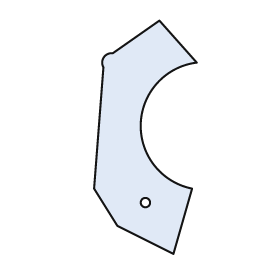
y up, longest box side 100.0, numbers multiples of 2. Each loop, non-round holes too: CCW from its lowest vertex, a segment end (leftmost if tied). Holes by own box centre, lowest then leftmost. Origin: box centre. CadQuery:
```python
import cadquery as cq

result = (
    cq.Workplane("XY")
    .moveTo(12.0, -50.0)
    .lineTo(20.0, -22.0)
    .threePointArc((-2.0, 6.0), (22.0, 32.0))
    .lineTo(6.0, 50.0)
    .lineTo(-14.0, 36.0)
    .threePointArc((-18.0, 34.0), (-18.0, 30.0))
    .lineTo(-22.0, -22.0)
    .lineTo(-12.0, -38.0)
    .close()
    .moveTo(0.0, -28.0)
    .circle(2.0)
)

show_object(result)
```